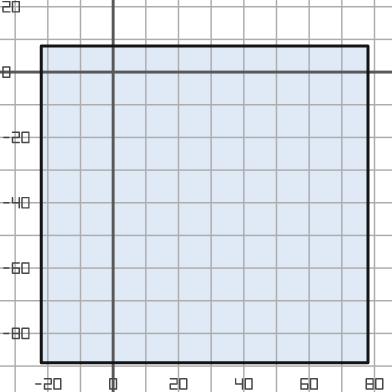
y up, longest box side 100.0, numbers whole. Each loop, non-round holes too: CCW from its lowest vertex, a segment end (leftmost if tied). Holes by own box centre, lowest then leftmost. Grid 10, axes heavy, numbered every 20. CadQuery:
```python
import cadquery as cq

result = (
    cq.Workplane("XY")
    .moveTo(-22.0, -89.0)
    .lineTo(78.0, -89.0)
    .lineTo(78.0, 8.0)
    .lineTo(-22.0, 8.0)
    .close()
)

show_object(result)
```